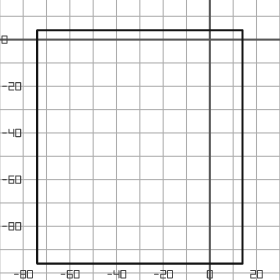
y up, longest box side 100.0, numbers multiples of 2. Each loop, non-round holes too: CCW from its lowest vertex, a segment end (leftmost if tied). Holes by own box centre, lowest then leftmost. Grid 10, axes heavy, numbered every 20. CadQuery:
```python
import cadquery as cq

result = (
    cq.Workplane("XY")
    .moveTo(-74.0, -96.0)
    .lineTo(14.0, -96.0)
    .lineTo(14.0, 4.0)
    .lineTo(-74.0, 4.0)
    .close()
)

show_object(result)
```